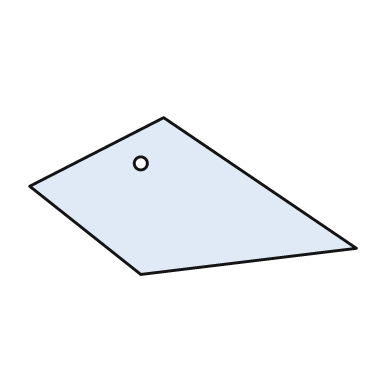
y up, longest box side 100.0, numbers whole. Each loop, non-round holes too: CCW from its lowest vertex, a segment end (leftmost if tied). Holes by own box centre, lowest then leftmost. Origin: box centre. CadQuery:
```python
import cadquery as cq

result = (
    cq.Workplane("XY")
    .moveTo(-16.0, -24.0)
    .lineTo(50.0, -16.0)
    .lineTo(-9.0, 24.0)
    .lineTo(-50.0, 3.0)
    .close()
    .moveTo(-16.0, 10.0)
    .circle(2.0)
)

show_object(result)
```